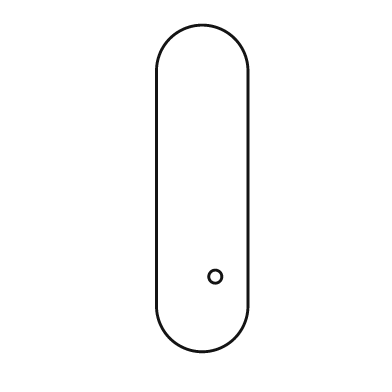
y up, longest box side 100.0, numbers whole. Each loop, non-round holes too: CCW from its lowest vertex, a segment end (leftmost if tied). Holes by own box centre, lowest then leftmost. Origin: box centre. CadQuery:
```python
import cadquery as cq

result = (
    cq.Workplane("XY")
    .moveTo(-14.0, -36.0)
    .threePointArc((0.0, -50.0), (14.0, -36.0))
    .lineTo(14.0, 36.0)
    .threePointArc((0.0, 50.0), (-14.0, 36.0))
    .close()
    .moveTo(4.0, -27.0)
    .circle(2.0)
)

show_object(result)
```